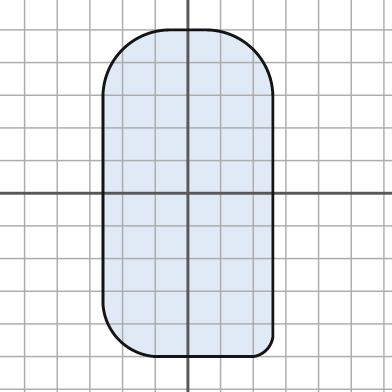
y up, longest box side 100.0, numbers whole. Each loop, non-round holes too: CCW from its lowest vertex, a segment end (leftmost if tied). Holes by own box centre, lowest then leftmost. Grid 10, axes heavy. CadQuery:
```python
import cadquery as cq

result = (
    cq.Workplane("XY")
    .moveTo(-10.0, -50.0)
    .lineTo(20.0, -50.0)
    .threePointArc((24.0, -48.0), (26.0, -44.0))
    .lineTo(26.0, 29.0)
    .threePointArc((20.0, 44.0), (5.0, 50.0))
    .lineTo(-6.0, 50.0)
    .threePointArc((-20.0, 44.0), (-26.0, 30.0))
    .lineTo(-26.0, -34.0)
    .threePointArc((-21.0, -45.0), (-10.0, -50.0))
    .close()
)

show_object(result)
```